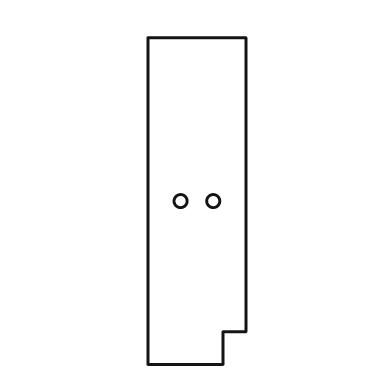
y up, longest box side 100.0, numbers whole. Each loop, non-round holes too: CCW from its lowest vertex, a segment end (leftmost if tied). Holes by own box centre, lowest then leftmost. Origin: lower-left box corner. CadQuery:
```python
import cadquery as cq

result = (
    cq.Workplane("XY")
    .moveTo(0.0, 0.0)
    .lineTo(23.0, 0.0)
    .lineTo(23.0, 10.0)
    .lineTo(30.0, 10.0)
    .lineTo(30.0, 100.0)
    .lineTo(0.0, 100.0)
    .close()
    .moveTo(10.0, 50.0)
    .circle(2.0)
    .moveTo(20.0, 50.0)
    .circle(2.0)
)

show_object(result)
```